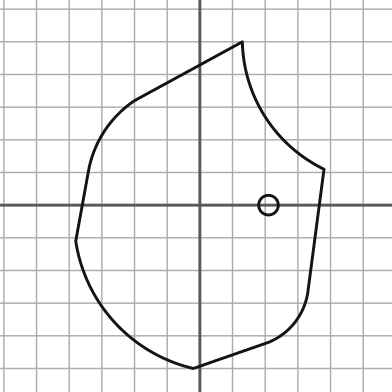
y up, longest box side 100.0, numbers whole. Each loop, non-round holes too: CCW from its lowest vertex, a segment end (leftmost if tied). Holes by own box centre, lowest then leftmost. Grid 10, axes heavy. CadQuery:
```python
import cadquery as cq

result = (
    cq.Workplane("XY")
    .moveTo(-2.0, -50.0)
    .lineTo(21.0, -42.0)
    .threePointArc((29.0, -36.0), (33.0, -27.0))
    .lineTo(38.0, 11.0)
    .threePointArc((20.0, 27.0), (13.0, 50.0))
    .lineTo(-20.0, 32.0)
    .threePointArc((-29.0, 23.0), (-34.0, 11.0))
    .lineTo(-38.0, -11.0)
    .threePointArc((-26.0, -36.0), (-2.0, -50.0))
    .close()
    .moveTo(21.0, 0.0)
    .circle(3.0)
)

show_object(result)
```